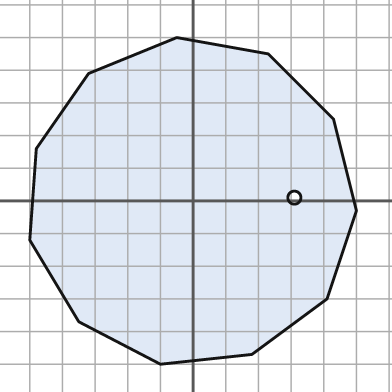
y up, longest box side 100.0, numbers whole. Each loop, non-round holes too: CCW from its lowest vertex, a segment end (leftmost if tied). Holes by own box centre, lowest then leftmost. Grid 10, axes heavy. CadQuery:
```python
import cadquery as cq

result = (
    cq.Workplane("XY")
    .moveTo(-10.0, -50.0)
    .lineTo(18.0, -47.0)
    .lineTo(41.0, -30.0)
    .lineTo(50.0, -3.0)
    .lineTo(43.0, 25.0)
    .lineTo(23.0, 45.0)
    .lineTo(-5.0, 50.0)
    .lineTo(-32.0, 39.0)
    .lineTo(-48.0, 16.0)
    .lineTo(-50.0, -12.0)
    .lineTo(-35.0, -37.0)
    .close()
    .moveTo(31.0, 1.0)
    .circle(2.0)
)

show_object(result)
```